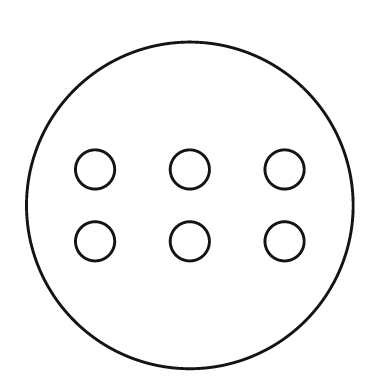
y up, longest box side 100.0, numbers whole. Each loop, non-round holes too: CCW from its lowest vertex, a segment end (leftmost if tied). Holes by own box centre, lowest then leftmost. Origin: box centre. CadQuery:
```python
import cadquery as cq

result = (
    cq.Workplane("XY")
    .moveTo(0.0, 0.0)
    .circle(50.0)
    .moveTo(-29.0, -11.0)
    .circle(6.0)
    .moveTo(0.0, -11.0)
    .circle(6.0)
    .moveTo(29.0, -11.0)
    .circle(6.0)
    .moveTo(-29.0, 11.0)
    .circle(6.0)
    .moveTo(0.0, 11.0)
    .circle(6.0)
    .moveTo(29.0, 11.0)
    .circle(6.0)
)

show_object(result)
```